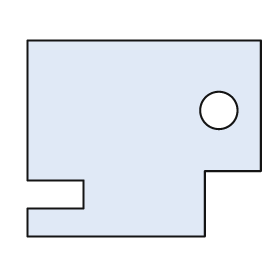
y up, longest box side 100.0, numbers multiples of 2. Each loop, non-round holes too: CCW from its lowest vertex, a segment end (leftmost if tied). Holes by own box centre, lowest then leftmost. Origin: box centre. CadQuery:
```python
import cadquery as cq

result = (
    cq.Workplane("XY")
    .moveTo(-50.0, -42.0)
    .lineTo(26.0, -42.0)
    .lineTo(26.0, -14.0)
    .lineTo(50.0, -14.0)
    .lineTo(50.0, 42.0)
    .lineTo(-50.0, 42.0)
    .lineTo(-50.0, -18.0)
    .lineTo(-26.0, -18.0)
    .lineTo(-26.0, -30.0)
    .lineTo(-50.0, -30.0)
    .close()
    .moveTo(32.0, 12.0)
    .circle(8.0)
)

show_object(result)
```